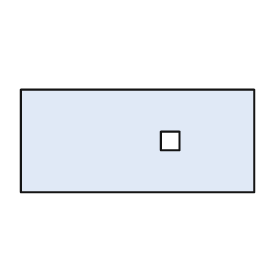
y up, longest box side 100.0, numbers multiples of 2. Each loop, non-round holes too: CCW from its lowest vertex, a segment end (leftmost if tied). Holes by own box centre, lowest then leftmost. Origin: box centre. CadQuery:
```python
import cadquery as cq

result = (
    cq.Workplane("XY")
    .moveTo(-50.0, -22.0)
    .lineTo(50.0, -22.0)
    .lineTo(50.0, 22.0)
    .lineTo(-50.0, 22.0)
    .close()
    .moveTo(10.0, -4.0)
    .lineTo(18.0, -4.0)
    .lineTo(18.0, 4.0)
    .lineTo(10.0, 4.0)
    .close()
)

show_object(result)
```